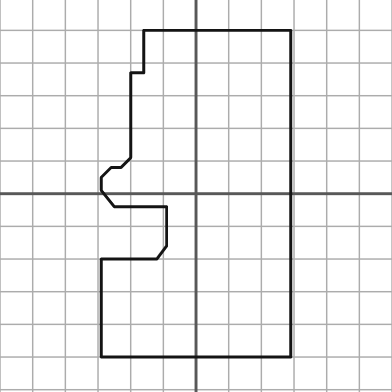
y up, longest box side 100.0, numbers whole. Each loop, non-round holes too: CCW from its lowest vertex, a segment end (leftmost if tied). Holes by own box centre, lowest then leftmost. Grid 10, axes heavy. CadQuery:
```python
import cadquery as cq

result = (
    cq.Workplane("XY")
    .moveTo(-29.0, -50.0)
    .lineTo(29.0, -50.0)
    .lineTo(29.0, 50.0)
    .lineTo(-16.0, 50.0)
    .lineTo(-16.0, 37.0)
    .lineTo(-20.0, 37.0)
    .lineTo(-20.0, 11.0)
    .lineTo(-23.0, 8.0)
    .lineTo(-26.0, 8.0)
    .lineTo(-29.0, 5.0)
    .lineTo(-29.0, 1.0)
    .lineTo(-25.0, -4.0)
    .lineTo(-9.0, -4.0)
    .lineTo(-9.0, -16.0)
    .lineTo(-12.0, -20.0)
    .lineTo(-29.0, -20.0)
    .close()
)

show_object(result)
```